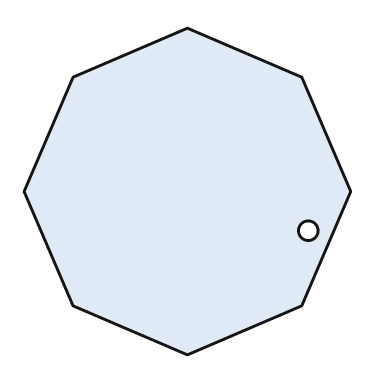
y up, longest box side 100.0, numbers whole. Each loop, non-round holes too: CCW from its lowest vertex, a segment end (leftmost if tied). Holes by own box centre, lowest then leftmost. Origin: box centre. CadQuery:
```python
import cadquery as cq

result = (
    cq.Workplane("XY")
    .moveTo(0.0, -50.0)
    .lineTo(35.0, -35.0)
    .lineTo(50.0, 0.0)
    .lineTo(35.0, 35.0)
    .lineTo(0.0, 50.0)
    .lineTo(-35.0, 35.0)
    .lineTo(-50.0, 0.0)
    .lineTo(-35.0, -35.0)
    .close()
    .moveTo(37.0, -12.0)
    .circle(3.0)
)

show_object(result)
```